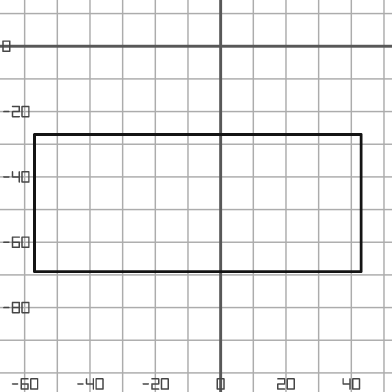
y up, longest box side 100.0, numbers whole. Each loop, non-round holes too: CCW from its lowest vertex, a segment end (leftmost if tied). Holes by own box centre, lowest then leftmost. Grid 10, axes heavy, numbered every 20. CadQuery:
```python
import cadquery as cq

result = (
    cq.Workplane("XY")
    .moveTo(-57.0, -69.0)
    .lineTo(43.0, -69.0)
    .lineTo(43.0, -27.0)
    .lineTo(-57.0, -27.0)
    .close()
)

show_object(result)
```